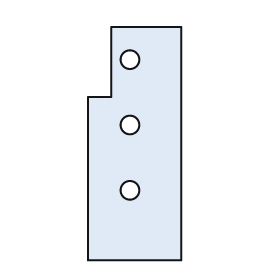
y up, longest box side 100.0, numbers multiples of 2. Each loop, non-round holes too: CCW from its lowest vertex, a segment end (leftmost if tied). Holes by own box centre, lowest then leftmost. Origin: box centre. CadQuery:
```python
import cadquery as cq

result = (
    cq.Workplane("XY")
    .moveTo(-20.0, -50.0)
    .lineTo(20.0, -50.0)
    .lineTo(20.0, 50.0)
    .lineTo(-10.0, 50.0)
    .lineTo(-10.0, 20.0)
    .lineTo(-20.0, 20.0)
    .close()
    .moveTo(-2.0, -20.0)
    .circle(4.0)
    .moveTo(-2.0, 8.0)
    .circle(4.0)
    .moveTo(-2.0, 36.0)
    .circle(4.0)
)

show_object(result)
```